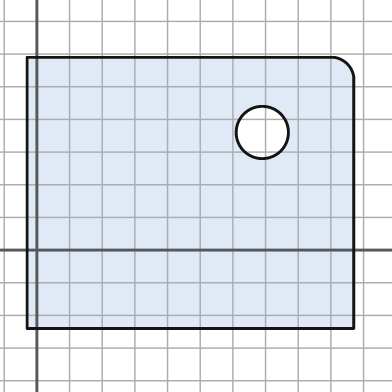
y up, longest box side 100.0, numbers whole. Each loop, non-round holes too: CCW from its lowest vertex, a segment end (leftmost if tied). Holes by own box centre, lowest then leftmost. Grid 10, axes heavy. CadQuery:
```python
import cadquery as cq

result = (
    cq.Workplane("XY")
    .moveTo(-3.0, -24.0)
    .lineTo(97.0, -24.0)
    .lineTo(97.0, 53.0)
    .threePointArc((95.0, 57.0), (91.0, 59.0))
    .lineTo(-3.0, 59.0)
    .close()
    .moveTo(69.0, 36.0)
    .circle(8.0)
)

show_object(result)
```